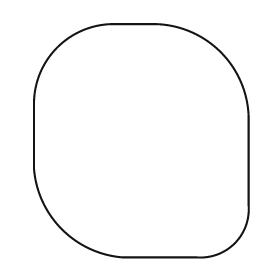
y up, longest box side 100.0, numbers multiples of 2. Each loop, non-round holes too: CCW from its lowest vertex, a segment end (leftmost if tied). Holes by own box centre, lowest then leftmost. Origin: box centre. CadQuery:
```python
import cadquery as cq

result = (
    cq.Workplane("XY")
    .moveTo(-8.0, -50.0)
    .lineTo(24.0, -50.0)
    .threePointArc((40.0, -44.0), (46.0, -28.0))
    .lineTo(46.0, 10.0)
    .threePointArc((34.0, 38.0), (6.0, 50.0))
    .lineTo(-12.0, 50.0)
    .threePointArc((-36.0, 40.0), (-46.0, 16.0))
    .lineTo(-46.0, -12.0)
    .threePointArc((-34.0, -38.0), (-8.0, -50.0))
    .close()
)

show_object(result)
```